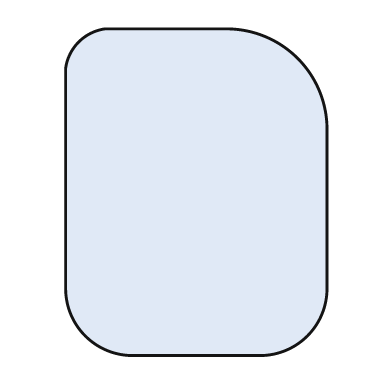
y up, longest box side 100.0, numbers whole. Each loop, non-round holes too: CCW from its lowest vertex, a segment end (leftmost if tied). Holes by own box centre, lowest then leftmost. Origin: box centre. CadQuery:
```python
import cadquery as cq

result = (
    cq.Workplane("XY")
    .moveTo(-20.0, -50.0)
    .lineTo(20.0, -50.0)
    .threePointArc((34.0, -44.0), (40.0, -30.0))
    .lineTo(40.0, 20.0)
    .threePointArc((31.0, 41.0), (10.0, 50.0))
    .lineTo(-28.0, 50.0)
    .threePointArc((-36.0, 46.0), (-40.0, 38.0))
    .lineTo(-40.0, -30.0)
    .threePointArc((-34.0, -44.0), (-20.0, -50.0))
    .close()
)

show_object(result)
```